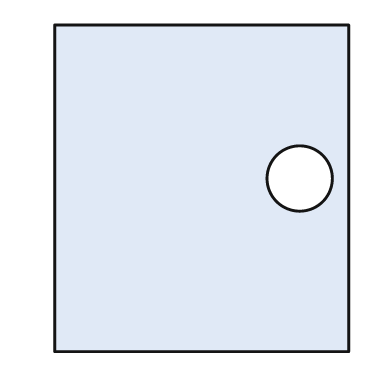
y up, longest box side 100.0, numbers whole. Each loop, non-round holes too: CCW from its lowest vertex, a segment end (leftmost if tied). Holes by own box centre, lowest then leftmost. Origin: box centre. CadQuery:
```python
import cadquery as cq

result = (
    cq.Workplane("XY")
    .moveTo(-45.0, -50.0)
    .lineTo(45.0, -50.0)
    .lineTo(45.0, 50.0)
    .lineTo(-45.0, 50.0)
    .close()
    .moveTo(30.0, 3.0)
    .circle(10.0)
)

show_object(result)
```